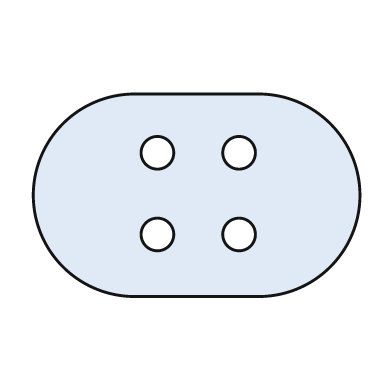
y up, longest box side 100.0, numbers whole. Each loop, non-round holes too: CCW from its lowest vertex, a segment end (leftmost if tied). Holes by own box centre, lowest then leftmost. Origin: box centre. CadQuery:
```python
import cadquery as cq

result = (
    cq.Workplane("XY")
    .moveTo(-19.0, -31.0)
    .lineTo(19.0, -31.0)
    .threePointArc((50.0, 0.0), (19.0, 31.0))
    .lineTo(-19.0, 31.0)
    .threePointArc((-50.0, 0.0), (-19.0, -31.0))
    .close()
    .moveTo(-12.0, -12.0)
    .circle(5.0)
    .moveTo(13.0, -12.0)
    .circle(5.0)
    .moveTo(-12.0, 13.0)
    .circle(5.0)
    .moveTo(13.0, 13.0)
    .circle(5.0)
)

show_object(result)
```